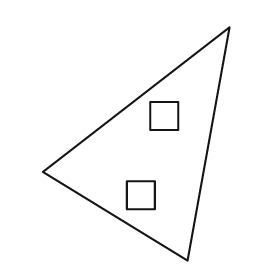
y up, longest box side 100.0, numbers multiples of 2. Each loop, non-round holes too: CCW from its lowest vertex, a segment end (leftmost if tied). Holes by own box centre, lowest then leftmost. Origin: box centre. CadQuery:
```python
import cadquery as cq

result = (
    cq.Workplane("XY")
    .moveTo(22.0, -50.0)
    .lineTo(40.0, 50.0)
    .lineTo(-40.0, -12.0)
    .close()
    .moveTo(-4.0, -28.0)
    .lineTo(8.0, -28.0)
    .lineTo(8.0, -16.0)
    .lineTo(-4.0, -16.0)
    .close()
    .moveTo(6.0, 6.0)
    .lineTo(18.0, 6.0)
    .lineTo(18.0, 18.0)
    .lineTo(6.0, 18.0)
    .close()
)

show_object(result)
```